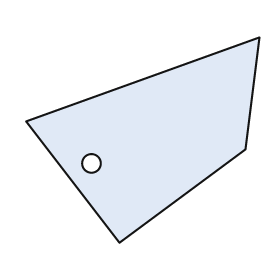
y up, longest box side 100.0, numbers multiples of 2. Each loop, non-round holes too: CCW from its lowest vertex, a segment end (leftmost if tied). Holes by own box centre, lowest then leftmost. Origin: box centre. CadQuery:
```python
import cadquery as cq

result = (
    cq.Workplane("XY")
    .moveTo(-10.0, -44.0)
    .lineTo(44.0, -4.0)
    .lineTo(50.0, 44.0)
    .lineTo(-50.0, 8.0)
    .close()
    .moveTo(-22.0, -10.0)
    .circle(4.0)
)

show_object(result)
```